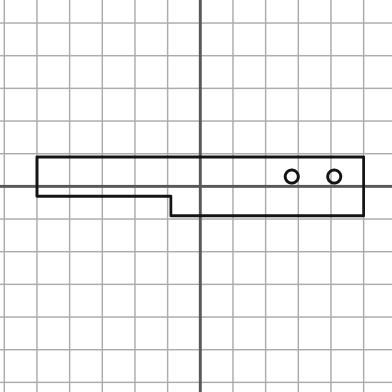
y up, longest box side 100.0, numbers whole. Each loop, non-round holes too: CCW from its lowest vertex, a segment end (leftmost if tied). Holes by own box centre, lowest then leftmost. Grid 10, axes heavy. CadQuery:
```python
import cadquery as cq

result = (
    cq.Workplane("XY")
    .moveTo(-9.0, -9.0)
    .lineTo(50.0, -9.0)
    .lineTo(50.0, 9.0)
    .lineTo(-50.0, 9.0)
    .lineTo(-50.0, -3.0)
    .lineTo(-9.0, -3.0)
    .close()
    .moveTo(28.0, 3.0)
    .circle(2.0)
    .moveTo(41.0, 3.0)
    .circle(2.0)
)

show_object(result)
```